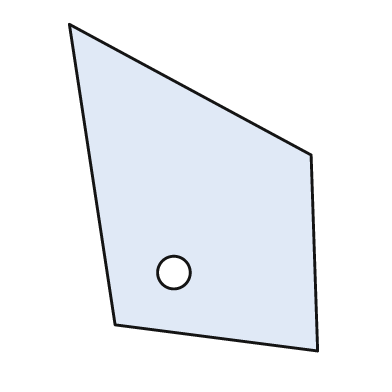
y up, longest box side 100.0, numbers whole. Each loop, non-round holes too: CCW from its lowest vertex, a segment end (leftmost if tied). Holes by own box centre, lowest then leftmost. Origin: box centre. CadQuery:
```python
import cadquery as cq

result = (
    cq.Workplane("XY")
    .moveTo(38.0, -50.0)
    .lineTo(36.0, 10.0)
    .lineTo(-38.0, 50.0)
    .lineTo(-24.0, -42.0)
    .close()
    .moveTo(-6.0, -26.0)
    .circle(5.0)
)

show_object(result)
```